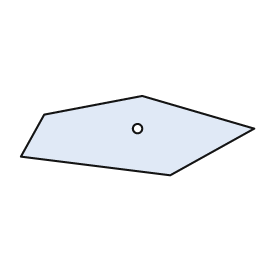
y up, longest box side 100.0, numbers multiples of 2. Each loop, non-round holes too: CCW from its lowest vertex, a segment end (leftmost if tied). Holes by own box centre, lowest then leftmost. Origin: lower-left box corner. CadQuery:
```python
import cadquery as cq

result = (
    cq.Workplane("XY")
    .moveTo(64.0, 0.0)
    .lineTo(100.0, 20.0)
    .lineTo(52.0, 34.0)
    .lineTo(10.0, 26.0)
    .lineTo(0.0, 8.0)
    .close()
    .moveTo(50.0, 20.0)
    .circle(2.0)
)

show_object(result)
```